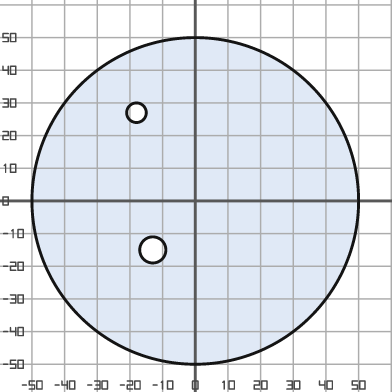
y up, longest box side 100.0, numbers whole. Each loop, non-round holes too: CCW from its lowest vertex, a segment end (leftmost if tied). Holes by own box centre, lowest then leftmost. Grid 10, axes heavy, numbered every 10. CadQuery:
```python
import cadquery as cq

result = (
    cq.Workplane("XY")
    .moveTo(0.0, 0.0)
    .circle(50.0)
    .moveTo(-13.0, -15.0)
    .circle(4.0)
    .moveTo(-18.0, 27.0)
    .circle(3.0)
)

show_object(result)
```